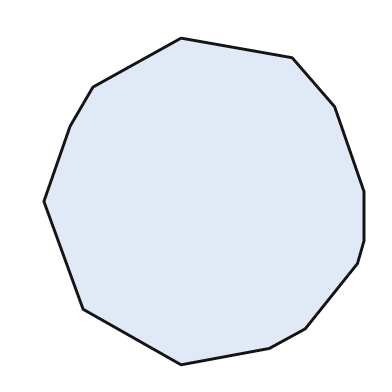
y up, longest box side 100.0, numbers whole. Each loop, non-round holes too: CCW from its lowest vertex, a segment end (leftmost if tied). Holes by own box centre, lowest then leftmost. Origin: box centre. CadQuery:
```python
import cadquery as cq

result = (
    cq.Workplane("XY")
    .moveTo(-7.0, -50.0)
    .lineTo(20.0, -45.0)
    .lineTo(31.0, -39.0)
    .lineTo(47.0, -19.0)
    .lineTo(49.0, -12.0)
    .lineTo(49.0, 3.0)
    .lineTo(40.0, 29.0)
    .lineTo(27.0, 44.0)
    .lineTo(-7.0, 50.0)
    .lineTo(-34.0, 35.0)
    .lineTo(-41.0, 23.0)
    .lineTo(-49.0, 0.0)
    .lineTo(-37.0, -33.0)
    .close()
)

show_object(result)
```